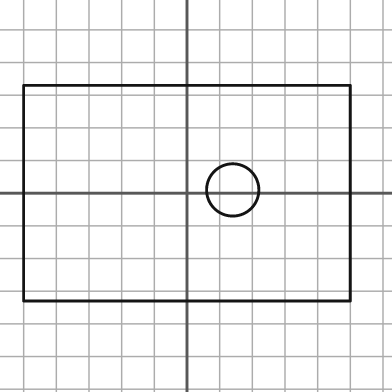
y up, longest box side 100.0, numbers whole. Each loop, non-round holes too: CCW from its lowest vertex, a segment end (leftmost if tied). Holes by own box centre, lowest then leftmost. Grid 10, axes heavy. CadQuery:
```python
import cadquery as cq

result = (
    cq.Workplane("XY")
    .moveTo(-50.0, -33.0)
    .lineTo(50.0, -33.0)
    .lineTo(50.0, 33.0)
    .lineTo(-50.0, 33.0)
    .close()
    .moveTo(14.0, 1.0)
    .circle(8.0)
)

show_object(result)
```